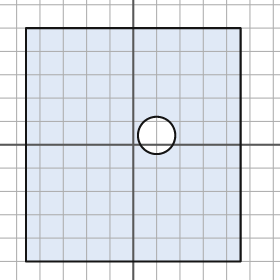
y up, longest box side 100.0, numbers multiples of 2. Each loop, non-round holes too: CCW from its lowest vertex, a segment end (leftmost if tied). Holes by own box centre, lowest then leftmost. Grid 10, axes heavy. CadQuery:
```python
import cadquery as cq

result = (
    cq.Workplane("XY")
    .moveTo(-46.0, -50.0)
    .lineTo(46.0, -50.0)
    .lineTo(46.0, 50.0)
    .lineTo(-46.0, 50.0)
    .close()
    .moveTo(10.0, 4.0)
    .circle(8.0)
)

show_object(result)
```